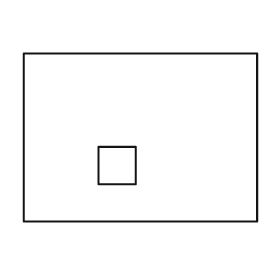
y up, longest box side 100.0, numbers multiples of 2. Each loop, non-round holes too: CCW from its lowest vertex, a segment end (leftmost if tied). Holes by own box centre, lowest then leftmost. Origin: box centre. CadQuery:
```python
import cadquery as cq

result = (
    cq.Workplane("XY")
    .moveTo(-50.0, -36.0)
    .lineTo(50.0, -36.0)
    .lineTo(50.0, 36.0)
    .lineTo(-50.0, 36.0)
    .close()
    .moveTo(-18.0, -20.0)
    .lineTo(-2.0, -20.0)
    .lineTo(-2.0, -4.0)
    .lineTo(-18.0, -4.0)
    .close()
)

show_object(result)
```